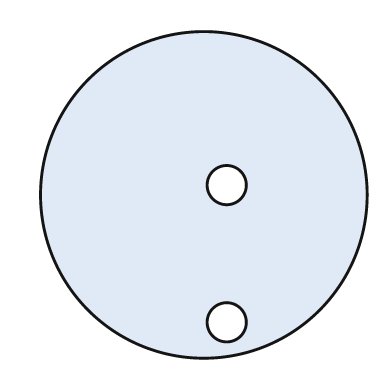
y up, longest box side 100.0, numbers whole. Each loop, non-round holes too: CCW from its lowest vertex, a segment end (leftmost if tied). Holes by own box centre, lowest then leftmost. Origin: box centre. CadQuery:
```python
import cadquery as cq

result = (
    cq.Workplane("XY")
    .moveTo(0.0, 0.0)
    .circle(50.0)
    .moveTo(7.0, -39.0)
    .circle(6.0)
    .moveTo(7.0, 3.0)
    .circle(6.0)
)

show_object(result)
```